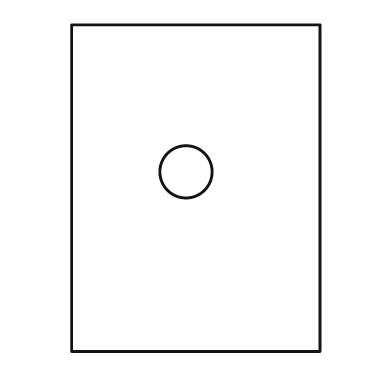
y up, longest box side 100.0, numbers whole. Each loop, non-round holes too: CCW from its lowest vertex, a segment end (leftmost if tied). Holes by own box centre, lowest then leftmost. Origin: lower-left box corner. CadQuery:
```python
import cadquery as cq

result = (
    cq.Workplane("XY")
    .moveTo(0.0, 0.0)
    .lineTo(76.0, 0.0)
    .lineTo(76.0, 100.0)
    .lineTo(0.0, 100.0)
    .close()
    .moveTo(35.0, 55.0)
    .circle(8.0)
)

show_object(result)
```